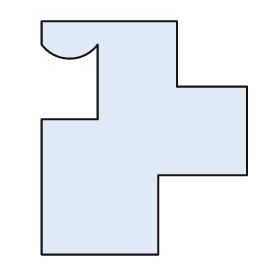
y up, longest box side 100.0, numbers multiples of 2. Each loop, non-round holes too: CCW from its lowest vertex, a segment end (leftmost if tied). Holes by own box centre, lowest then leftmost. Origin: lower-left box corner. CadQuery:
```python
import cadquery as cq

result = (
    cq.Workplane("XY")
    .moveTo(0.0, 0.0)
    .lineTo(50.0, 0.0)
    .lineTo(50.0, 34.0)
    .lineTo(88.0, 34.0)
    .lineTo(88.0, 72.0)
    .lineTo(58.0, 72.0)
    .lineTo(58.0, 100.0)
    .lineTo(0.0, 100.0)
    .lineTo(0.0, 90.0)
    .threePointArc((12.0, 84.0), (24.0, 90.0))
    .lineTo(24.0, 58.0)
    .lineTo(0.0, 58.0)
    .close()
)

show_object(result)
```